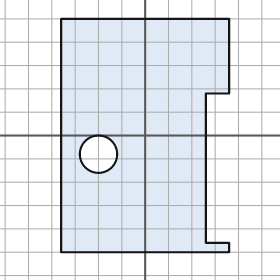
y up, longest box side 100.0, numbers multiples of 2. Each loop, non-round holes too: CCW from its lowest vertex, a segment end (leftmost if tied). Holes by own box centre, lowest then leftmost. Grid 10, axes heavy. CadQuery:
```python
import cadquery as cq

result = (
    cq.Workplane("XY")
    .moveTo(-36.0, -50.0)
    .lineTo(36.0, -50.0)
    .lineTo(36.0, -46.0)
    .lineTo(26.0, -46.0)
    .lineTo(26.0, 18.0)
    .lineTo(36.0, 18.0)
    .lineTo(36.0, 50.0)
    .lineTo(-36.0, 50.0)
    .close()
    .moveTo(-20.0, -8.0)
    .circle(8.0)
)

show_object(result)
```